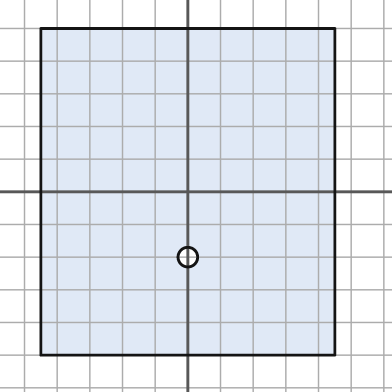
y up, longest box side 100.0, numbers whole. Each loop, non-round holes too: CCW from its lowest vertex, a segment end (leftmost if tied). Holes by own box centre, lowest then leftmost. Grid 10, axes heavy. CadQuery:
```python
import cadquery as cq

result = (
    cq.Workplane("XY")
    .moveTo(-45.0, -50.0)
    .lineTo(45.0, -50.0)
    .lineTo(45.0, 50.0)
    .lineTo(-45.0, 50.0)
    .close()
    .moveTo(0.0, -20.0)
    .circle(3.0)
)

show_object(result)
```